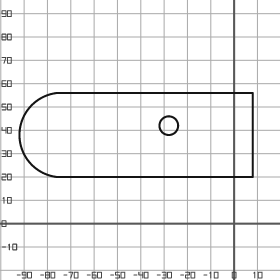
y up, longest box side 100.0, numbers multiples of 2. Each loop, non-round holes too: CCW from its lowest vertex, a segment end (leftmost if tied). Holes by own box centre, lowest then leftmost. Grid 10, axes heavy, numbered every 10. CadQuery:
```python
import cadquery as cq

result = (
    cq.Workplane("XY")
    .moveTo(-76.0, 20.0)
    .lineTo(8.0, 20.0)
    .lineTo(8.0, 56.0)
    .lineTo(-76.0, 56.0)
    .threePointArc((-92.0, 38.0), (-76.0, 20.0))
    .close()
    .moveTo(-28.0, 42.0)
    .circle(4.0)
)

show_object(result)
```